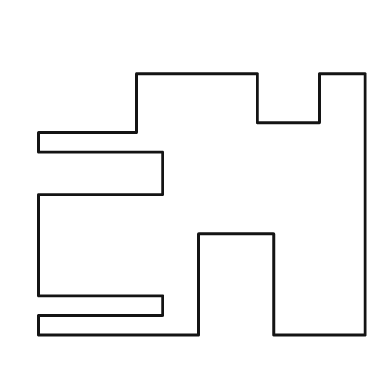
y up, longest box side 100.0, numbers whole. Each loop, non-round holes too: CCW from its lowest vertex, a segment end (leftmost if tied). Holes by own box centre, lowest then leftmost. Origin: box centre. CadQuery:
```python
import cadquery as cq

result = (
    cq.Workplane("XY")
    .moveTo(-50.0, -40.0)
    .lineTo(-1.0, -40.0)
    .lineTo(-1.0, -9.0)
    .lineTo(22.0, -9.0)
    .lineTo(22.0, -40.0)
    .lineTo(50.0, -40.0)
    .lineTo(50.0, 40.0)
    .lineTo(36.0, 40.0)
    .lineTo(36.0, 25.0)
    .lineTo(17.0, 25.0)
    .lineTo(17.0, 40.0)
    .lineTo(-20.0, 40.0)
    .lineTo(-20.0, 22.0)
    .lineTo(-50.0, 22.0)
    .lineTo(-50.0, 16.0)
    .lineTo(-12.0, 16.0)
    .lineTo(-12.0, 3.0)
    .lineTo(-50.0, 3.0)
    .lineTo(-50.0, -28.0)
    .lineTo(-12.0, -28.0)
    .lineTo(-12.0, -34.0)
    .lineTo(-50.0, -34.0)
    .close()
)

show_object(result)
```